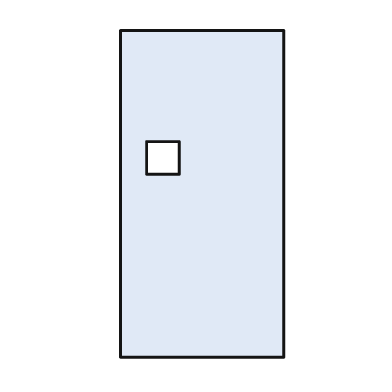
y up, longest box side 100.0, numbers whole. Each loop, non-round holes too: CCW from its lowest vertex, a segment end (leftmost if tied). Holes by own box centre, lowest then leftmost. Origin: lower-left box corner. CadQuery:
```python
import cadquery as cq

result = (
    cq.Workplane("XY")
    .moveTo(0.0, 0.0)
    .lineTo(50.0, 0.0)
    .lineTo(50.0, 100.0)
    .lineTo(0.0, 100.0)
    .close()
    .moveTo(8.0, 56.0)
    .lineTo(18.0, 56.0)
    .lineTo(18.0, 66.0)
    .lineTo(8.0, 66.0)
    .close()
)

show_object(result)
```